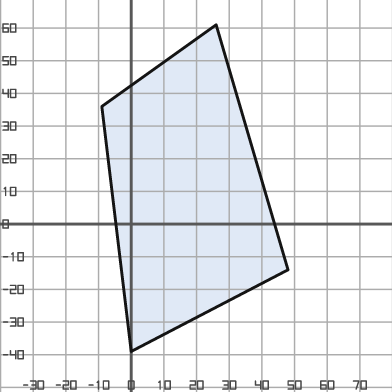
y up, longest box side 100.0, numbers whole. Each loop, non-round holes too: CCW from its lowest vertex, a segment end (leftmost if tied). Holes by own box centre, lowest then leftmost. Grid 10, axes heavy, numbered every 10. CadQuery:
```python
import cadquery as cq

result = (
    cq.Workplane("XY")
    .moveTo(0.0, -39.0)
    .lineTo(48.0, -14.0)
    .lineTo(26.0, 61.0)
    .lineTo(-9.0, 36.0)
    .close()
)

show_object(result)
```